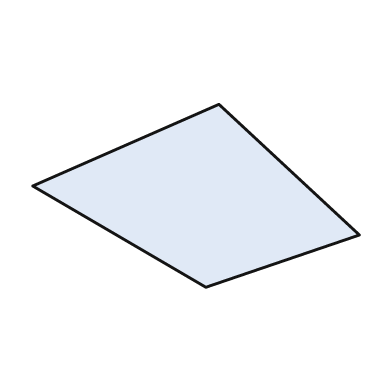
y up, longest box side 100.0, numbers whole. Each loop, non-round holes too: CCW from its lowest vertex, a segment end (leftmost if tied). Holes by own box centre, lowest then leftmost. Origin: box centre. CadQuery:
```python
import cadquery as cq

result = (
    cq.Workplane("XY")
    .moveTo(3.0, -28.0)
    .lineTo(50.0, -12.0)
    .lineTo(7.0, 28.0)
    .lineTo(-50.0, 3.0)
    .close()
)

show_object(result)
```